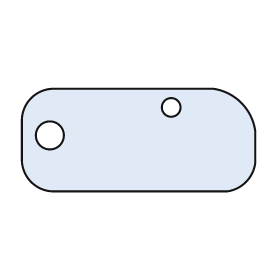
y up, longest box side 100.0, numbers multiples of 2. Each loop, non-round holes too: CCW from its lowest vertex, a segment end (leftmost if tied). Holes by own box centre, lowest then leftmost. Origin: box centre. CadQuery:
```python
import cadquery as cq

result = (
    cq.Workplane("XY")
    .moveTo(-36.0, -22.0)
    .lineTo(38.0, -22.0)
    .threePointArc((46.0, -18.0), (50.0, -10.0))
    .lineTo(50.0, 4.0)
    .threePointArc((44.0, 16.0), (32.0, 22.0))
    .lineTo(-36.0, 22.0)
    .threePointArc((-46.0, 18.0), (-50.0, 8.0))
    .lineTo(-50.0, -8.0)
    .threePointArc((-46.0, -18.0), (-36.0, -22.0))
    .close()
    .moveTo(-38.0, 2.0)
    .circle(6.0)
    .moveTo(14.0, 14.0)
    .circle(4.0)
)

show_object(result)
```